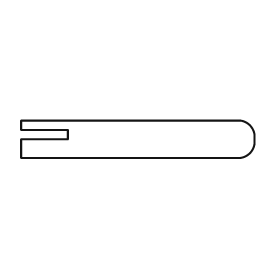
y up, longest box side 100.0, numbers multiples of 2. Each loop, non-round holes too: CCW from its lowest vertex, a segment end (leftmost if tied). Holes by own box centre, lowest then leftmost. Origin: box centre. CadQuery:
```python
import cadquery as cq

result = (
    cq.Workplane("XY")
    .moveTo(-50.0, -8.0)
    .lineTo(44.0, -8.0)
    .threePointArc((48.0, -6.0), (50.0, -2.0))
    .lineTo(50.0, 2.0)
    .threePointArc((48.0, 6.0), (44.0, 8.0))
    .lineTo(-50.0, 8.0)
    .lineTo(-50.0, 4.0)
    .lineTo(-30.0, 4.0)
    .lineTo(-30.0, 0.0)
    .lineTo(-50.0, 0.0)
    .close()
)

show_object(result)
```